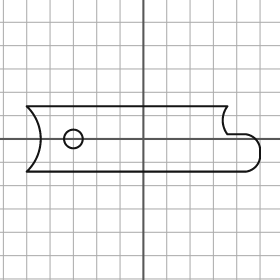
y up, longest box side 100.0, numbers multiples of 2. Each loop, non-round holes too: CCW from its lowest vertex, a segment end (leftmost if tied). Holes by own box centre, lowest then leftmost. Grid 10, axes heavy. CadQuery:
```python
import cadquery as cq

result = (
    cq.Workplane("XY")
    .moveTo(-50.0, -14.0)
    .lineTo(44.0, -14.0)
    .threePointArc((48.0, -12.0), (50.0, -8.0))
    .lineTo(50.0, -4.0)
    .threePointArc((48.0, 0.0), (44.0, 2.0))
    .lineTo(36.0, 2.0)
    .threePointArc((34.0, 8.0), (36.0, 14.0))
    .lineTo(-50.0, 14.0)
    .threePointArc((-44.0, 0.0), (-50.0, -14.0))
    .close()
    .moveTo(-30.0, 0.0)
    .circle(4.0)
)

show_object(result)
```